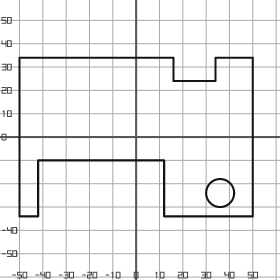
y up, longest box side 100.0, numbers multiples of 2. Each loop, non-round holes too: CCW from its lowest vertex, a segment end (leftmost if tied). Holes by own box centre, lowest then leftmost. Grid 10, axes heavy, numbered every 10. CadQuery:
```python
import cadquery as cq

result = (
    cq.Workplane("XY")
    .moveTo(-50.0, -34.0)
    .lineTo(-42.0, -34.0)
    .lineTo(-42.0, -10.0)
    .lineTo(12.0, -10.0)
    .lineTo(12.0, -34.0)
    .lineTo(50.0, -34.0)
    .lineTo(50.0, 34.0)
    .lineTo(34.0, 34.0)
    .lineTo(34.0, 24.0)
    .lineTo(16.0, 24.0)
    .lineTo(16.0, 34.0)
    .lineTo(-50.0, 34.0)
    .close()
    .moveTo(36.0, -24.0)
    .circle(6.0)
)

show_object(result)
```